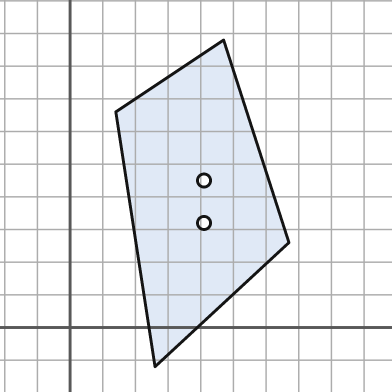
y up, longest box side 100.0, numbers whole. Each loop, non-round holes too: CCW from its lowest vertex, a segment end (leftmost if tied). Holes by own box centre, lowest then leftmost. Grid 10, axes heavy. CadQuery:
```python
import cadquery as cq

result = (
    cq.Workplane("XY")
    .moveTo(26.0, -12.0)
    .lineTo(67.0, 26.0)
    .lineTo(47.0, 88.0)
    .lineTo(14.0, 66.0)
    .close()
    .moveTo(41.0, 32.0)
    .circle(2.0)
    .moveTo(41.0, 45.0)
    .circle(2.0)
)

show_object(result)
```